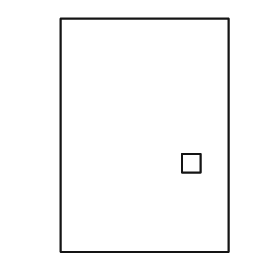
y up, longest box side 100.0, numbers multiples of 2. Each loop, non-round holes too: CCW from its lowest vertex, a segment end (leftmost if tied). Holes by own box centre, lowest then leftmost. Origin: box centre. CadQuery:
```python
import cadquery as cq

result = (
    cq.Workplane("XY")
    .moveTo(-36.0, -50.0)
    .lineTo(36.0, -50.0)
    .lineTo(36.0, 50.0)
    .lineTo(-36.0, 50.0)
    .close()
    .moveTo(16.0, -16.0)
    .lineTo(24.0, -16.0)
    .lineTo(24.0, -8.0)
    .lineTo(16.0, -8.0)
    .close()
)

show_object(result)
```